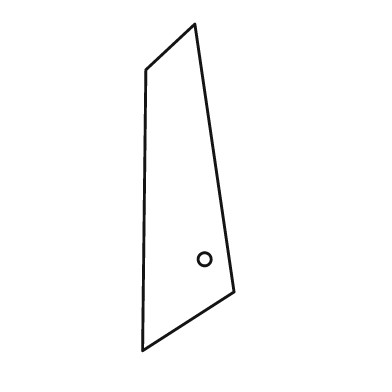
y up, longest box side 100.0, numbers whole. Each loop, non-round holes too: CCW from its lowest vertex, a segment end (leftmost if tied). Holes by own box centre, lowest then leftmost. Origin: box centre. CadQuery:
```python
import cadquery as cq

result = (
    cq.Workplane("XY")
    .moveTo(-14.0, -50.0)
    .lineTo(14.0, -32.0)
    .lineTo(2.0, 50.0)
    .lineTo(-13.0, 36.0)
    .close()
    .moveTo(5.0, -22.0)
    .circle(2.0)
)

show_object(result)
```